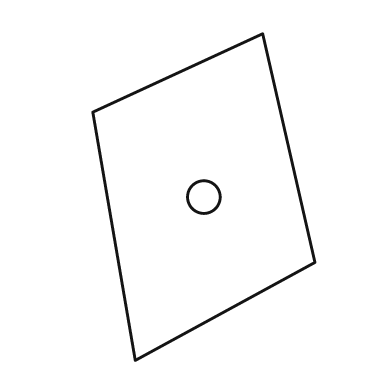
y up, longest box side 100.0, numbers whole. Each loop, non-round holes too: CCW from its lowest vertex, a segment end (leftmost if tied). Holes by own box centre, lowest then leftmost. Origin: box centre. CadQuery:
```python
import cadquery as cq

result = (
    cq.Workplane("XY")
    .moveTo(-21.0, -50.0)
    .lineTo(34.0, -20.0)
    .lineTo(18.0, 50.0)
    .lineTo(-34.0, 26.0)
    .close()
    .moveTo(0.0, 0.0)
    .circle(5.0)
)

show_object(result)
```